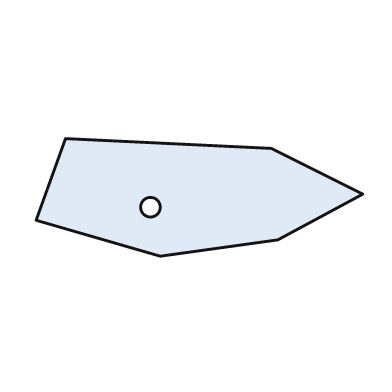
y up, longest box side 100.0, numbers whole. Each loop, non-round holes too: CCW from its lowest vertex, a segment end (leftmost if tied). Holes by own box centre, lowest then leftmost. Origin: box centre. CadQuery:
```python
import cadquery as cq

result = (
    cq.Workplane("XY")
    .moveTo(-12.0, -18.0)
    .lineTo(24.0, -13.0)
    .lineTo(50.0, 1.0)
    .lineTo(22.0, 15.0)
    .lineTo(-41.0, 18.0)
    .lineTo(-50.0, -7.0)
    .close()
    .moveTo(-15.0, -3.0)
    .circle(3.0)
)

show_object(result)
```